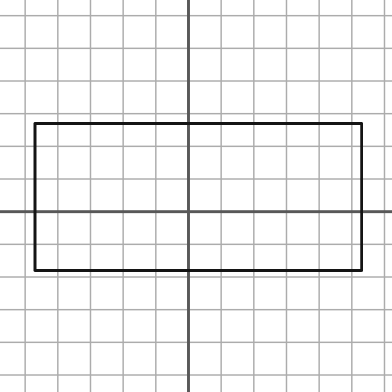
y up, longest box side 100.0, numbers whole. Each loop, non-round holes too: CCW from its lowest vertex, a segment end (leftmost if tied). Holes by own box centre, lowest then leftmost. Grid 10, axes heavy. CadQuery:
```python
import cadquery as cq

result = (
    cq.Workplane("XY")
    .moveTo(-47.0, -18.0)
    .lineTo(53.0, -18.0)
    .lineTo(53.0, 27.0)
    .lineTo(-47.0, 27.0)
    .close()
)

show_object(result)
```